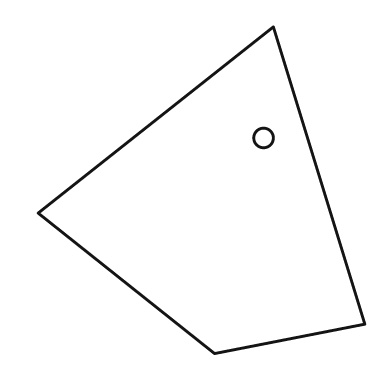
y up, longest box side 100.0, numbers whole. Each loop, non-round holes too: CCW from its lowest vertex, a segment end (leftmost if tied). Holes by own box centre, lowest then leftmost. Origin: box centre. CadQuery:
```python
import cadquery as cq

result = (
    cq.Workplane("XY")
    .moveTo(4.0, -50.0)
    .lineTo(50.0, -41.0)
    .lineTo(22.0, 50.0)
    .lineTo(-50.0, -7.0)
    .close()
    .moveTo(19.0, 16.0)
    .circle(3.0)
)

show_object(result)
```